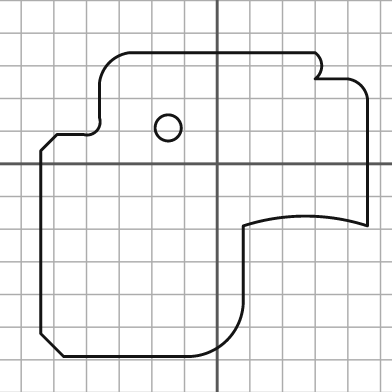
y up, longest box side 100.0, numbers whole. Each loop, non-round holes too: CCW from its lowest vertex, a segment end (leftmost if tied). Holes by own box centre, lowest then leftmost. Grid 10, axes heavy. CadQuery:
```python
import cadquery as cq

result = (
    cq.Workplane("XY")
    .moveTo(-47.0, -59.0)
    .lineTo(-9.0, -59.0)
    .threePointArc((3.0, -54.0), (8.0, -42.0))
    .lineTo(8.0, -19.0)
    .threePointArc((27.0, -16.0), (46.0, -19.0))
    .lineTo(46.0, 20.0)
    .threePointArc((44.0, 24.0), (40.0, 26.0))
    .lineTo(30.0, 26.0)
    .threePointArc((32.0, 30.0), (30.0, 34.0))
    .lineTo(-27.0, 34.0)
    .threePointArc((-33.0, 31.0), (-36.0, 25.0))
    .lineTo(-36.0, 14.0)
    .threePointArc((-37.0, 10.0), (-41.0, 9.0))
    .lineTo(-49.0, 9.0)
    .lineTo(-54.0, 4.0)
    .lineTo(-54.0, -52.0)
    .close()
    .moveTo(-15.0, 11.0)
    .circle(4.0)
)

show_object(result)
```